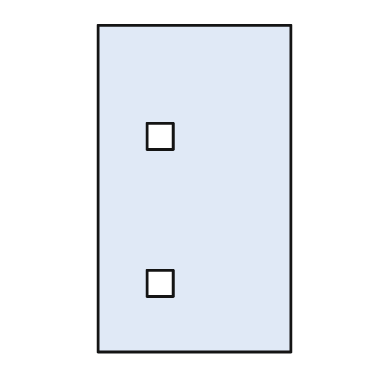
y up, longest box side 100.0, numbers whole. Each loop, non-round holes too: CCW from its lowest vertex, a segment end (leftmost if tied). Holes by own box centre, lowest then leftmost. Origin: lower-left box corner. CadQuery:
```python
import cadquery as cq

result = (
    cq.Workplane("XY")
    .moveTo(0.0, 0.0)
    .lineTo(59.0, 0.0)
    .lineTo(59.0, 100.0)
    .lineTo(0.0, 100.0)
    .close()
    .moveTo(15.0, 17.0)
    .lineTo(23.0, 17.0)
    .lineTo(23.0, 25.0)
    .lineTo(15.0, 25.0)
    .close()
    .moveTo(15.0, 62.0)
    .lineTo(23.0, 62.0)
    .lineTo(23.0, 70.0)
    .lineTo(15.0, 70.0)
    .close()
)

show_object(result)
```